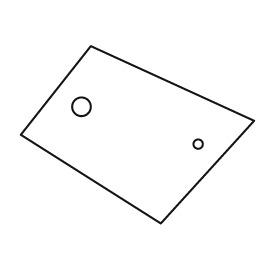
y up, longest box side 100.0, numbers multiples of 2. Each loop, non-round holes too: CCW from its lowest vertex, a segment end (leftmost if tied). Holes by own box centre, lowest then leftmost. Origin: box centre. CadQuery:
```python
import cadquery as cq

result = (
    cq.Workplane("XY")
    .moveTo(10.0, -38.0)
    .lineTo(50.0, 6.0)
    .lineTo(-20.0, 38.0)
    .lineTo(-50.0, 0.0)
    .close()
    .moveTo(26.0, -4.0)
    .circle(2.0)
    .moveTo(-24.0, 12.0)
    .circle(4.0)
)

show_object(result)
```